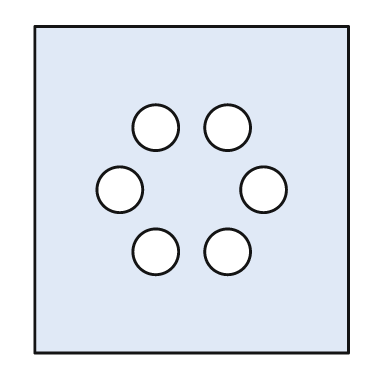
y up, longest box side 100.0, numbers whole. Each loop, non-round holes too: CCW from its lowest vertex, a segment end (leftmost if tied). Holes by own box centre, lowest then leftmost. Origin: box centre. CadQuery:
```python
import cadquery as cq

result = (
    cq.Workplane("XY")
    .moveTo(-48.0, -50.0)
    .lineTo(48.0, -50.0)
    .lineTo(48.0, 50.0)
    .lineTo(-48.0, 50.0)
    .close()
    .moveTo(-11.0, -19.0)
    .circle(7.0)
    .moveTo(11.0, -19.0)
    .circle(7.0)
    .moveTo(-22.0, 0.0)
    .circle(7.0)
    .moveTo(22.0, 0.0)
    .circle(7.0)
    .moveTo(-11.0, 19.0)
    .circle(7.0)
    .moveTo(11.0, 19.0)
    .circle(7.0)
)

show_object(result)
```